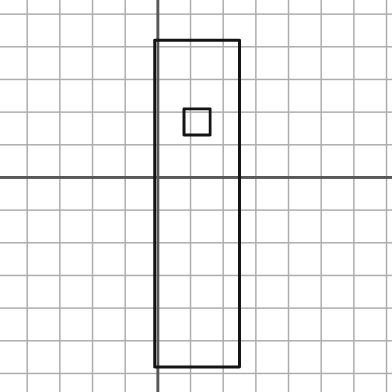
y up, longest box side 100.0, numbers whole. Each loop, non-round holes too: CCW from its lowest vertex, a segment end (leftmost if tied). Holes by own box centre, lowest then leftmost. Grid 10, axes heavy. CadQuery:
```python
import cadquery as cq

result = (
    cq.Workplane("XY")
    .moveTo(-1.0, -58.0)
    .lineTo(25.0, -58.0)
    .lineTo(25.0, 42.0)
    .lineTo(-1.0, 42.0)
    .close()
    .moveTo(8.0, 13.0)
    .lineTo(16.0, 13.0)
    .lineTo(16.0, 21.0)
    .lineTo(8.0, 21.0)
    .close()
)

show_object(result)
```